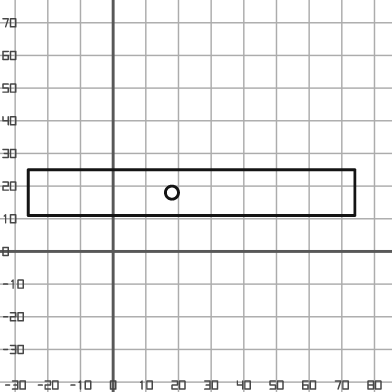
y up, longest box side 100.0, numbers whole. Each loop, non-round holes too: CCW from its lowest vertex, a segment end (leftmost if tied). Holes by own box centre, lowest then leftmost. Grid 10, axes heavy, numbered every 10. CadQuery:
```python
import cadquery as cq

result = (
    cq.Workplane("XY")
    .moveTo(-26.0, 11.0)
    .lineTo(74.0, 11.0)
    .lineTo(74.0, 25.0)
    .lineTo(-26.0, 25.0)
    .close()
    .moveTo(18.0, 18.0)
    .circle(2.0)
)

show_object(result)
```